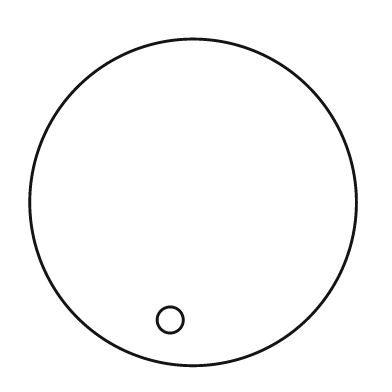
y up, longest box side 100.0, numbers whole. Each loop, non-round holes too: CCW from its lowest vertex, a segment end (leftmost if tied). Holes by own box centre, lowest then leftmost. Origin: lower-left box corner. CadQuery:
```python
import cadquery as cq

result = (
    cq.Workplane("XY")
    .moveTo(50.0, 50.0)
    .circle(50.0)
    .moveTo(43.0, 14.0)
    .circle(4.0)
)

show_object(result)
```